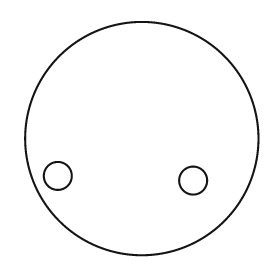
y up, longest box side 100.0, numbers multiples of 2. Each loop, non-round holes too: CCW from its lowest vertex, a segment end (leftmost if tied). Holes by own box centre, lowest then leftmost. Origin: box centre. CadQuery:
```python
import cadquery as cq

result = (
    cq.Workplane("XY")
    .moveTo(0.0, 0.0)
    .circle(50.0)
    .moveTo(22.0, -18.0)
    .circle(6.0)
    .moveTo(-36.0, -16.0)
    .circle(6.0)
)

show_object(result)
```